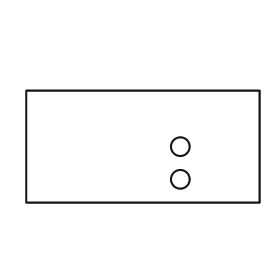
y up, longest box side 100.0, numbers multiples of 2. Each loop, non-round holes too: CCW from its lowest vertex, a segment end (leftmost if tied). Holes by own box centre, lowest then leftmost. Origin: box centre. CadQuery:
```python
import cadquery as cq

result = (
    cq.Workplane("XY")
    .moveTo(-50.0, -24.0)
    .lineTo(50.0, -24.0)
    .lineTo(50.0, 24.0)
    .lineTo(-50.0, 24.0)
    .close()
    .moveTo(16.0, -14.0)
    .circle(4.0)
    .moveTo(16.0, 0.0)
    .circle(4.0)
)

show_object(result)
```